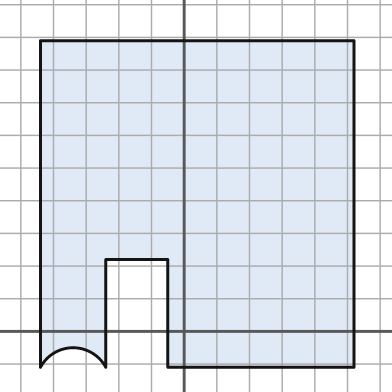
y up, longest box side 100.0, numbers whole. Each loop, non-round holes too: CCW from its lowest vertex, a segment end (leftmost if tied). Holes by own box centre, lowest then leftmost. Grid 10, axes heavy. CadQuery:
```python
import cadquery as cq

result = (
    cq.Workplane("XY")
    .moveTo(-44.0, -11.0)
    .threePointArc((-34.0, -5.0), (-24.0, -11.0))
    .lineTo(-24.0, 22.0)
    .lineTo(-5.0, 22.0)
    .lineTo(-5.0, -11.0)
    .lineTo(52.0, -11.0)
    .lineTo(52.0, 89.0)
    .lineTo(-44.0, 89.0)
    .close()
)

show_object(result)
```